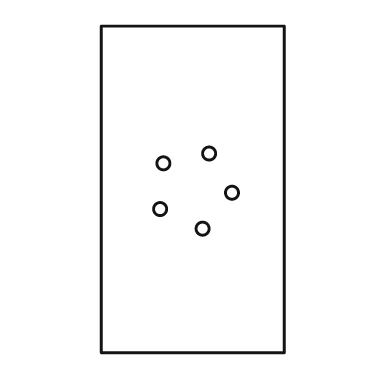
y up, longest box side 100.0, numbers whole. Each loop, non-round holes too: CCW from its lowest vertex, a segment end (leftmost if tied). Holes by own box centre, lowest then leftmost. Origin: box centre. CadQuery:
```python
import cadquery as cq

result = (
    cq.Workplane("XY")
    .moveTo(-28.0, -50.0)
    .lineTo(28.0, -50.0)
    .lineTo(28.0, 50.0)
    .lineTo(-28.0, 50.0)
    .close()
    .moveTo(3.0, -12.0)
    .circle(2.0)
    .moveTo(-10.0, -6.0)
    .circle(2.0)
    .moveTo(12.0, -1.0)
    .circle(2.0)
    .moveTo(-9.0, 8.0)
    .circle(2.0)
    .moveTo(5.0, 11.0)
    .circle(2.0)
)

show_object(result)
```